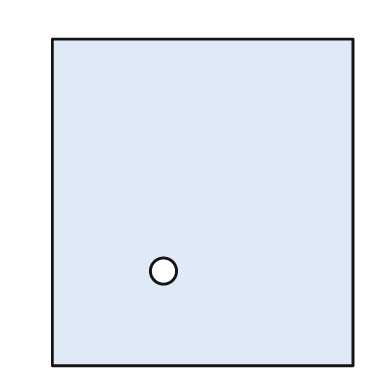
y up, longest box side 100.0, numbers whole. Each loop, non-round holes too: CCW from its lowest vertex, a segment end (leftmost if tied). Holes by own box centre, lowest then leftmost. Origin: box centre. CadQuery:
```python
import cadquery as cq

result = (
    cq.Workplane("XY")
    .moveTo(-46.0, -50.0)
    .lineTo(46.0, -50.0)
    .lineTo(46.0, 50.0)
    .lineTo(-46.0, 50.0)
    .close()
    .moveTo(-12.0, -21.0)
    .circle(4.0)
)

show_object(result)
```